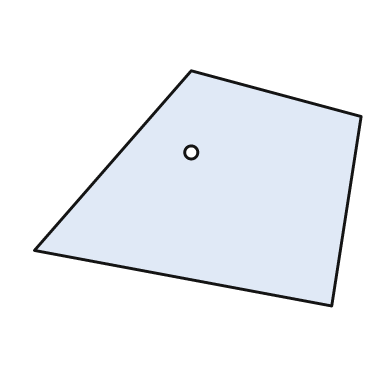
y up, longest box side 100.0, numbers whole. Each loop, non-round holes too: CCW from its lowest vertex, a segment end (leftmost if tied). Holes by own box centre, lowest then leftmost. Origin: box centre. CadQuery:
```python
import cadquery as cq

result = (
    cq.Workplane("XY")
    .moveTo(41.0, -36.0)
    .lineTo(50.0, 22.0)
    .lineTo(-2.0, 36.0)
    .lineTo(-50.0, -19.0)
    .close()
    .moveTo(-2.0, 11.0)
    .circle(2.0)
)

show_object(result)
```